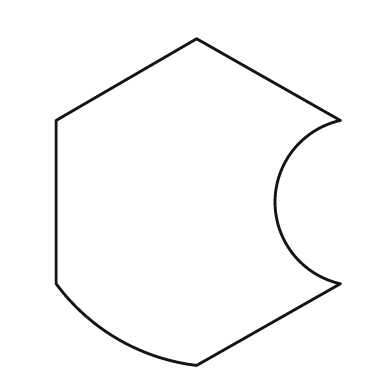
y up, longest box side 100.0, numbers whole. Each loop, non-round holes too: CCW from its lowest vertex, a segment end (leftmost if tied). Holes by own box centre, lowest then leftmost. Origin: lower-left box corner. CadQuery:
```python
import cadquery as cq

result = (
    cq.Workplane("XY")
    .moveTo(43.0, 0.0)
    .lineTo(87.0, 25.0)
    .threePointArc((67.0, 50.0), (87.0, 75.0))
    .lineTo(43.0, 100.0)
    .lineTo(0.0, 75.0)
    .lineTo(0.0, 25.0)
    .threePointArc((19.0, 8.0), (43.0, 0.0))
    .close()
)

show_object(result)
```